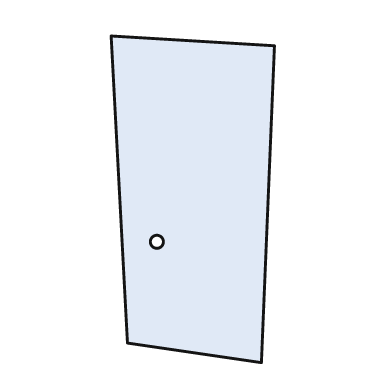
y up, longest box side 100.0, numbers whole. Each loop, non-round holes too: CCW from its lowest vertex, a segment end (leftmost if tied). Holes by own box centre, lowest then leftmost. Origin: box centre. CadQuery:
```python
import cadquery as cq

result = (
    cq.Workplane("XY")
    .moveTo(21.0, -50.0)
    .lineTo(25.0, 47.0)
    .lineTo(-25.0, 50.0)
    .lineTo(-20.0, -44.0)
    .close()
    .moveTo(-11.0, -13.0)
    .circle(2.0)
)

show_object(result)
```